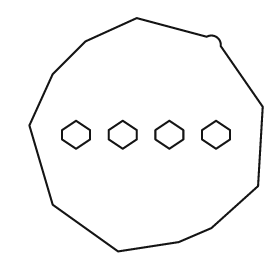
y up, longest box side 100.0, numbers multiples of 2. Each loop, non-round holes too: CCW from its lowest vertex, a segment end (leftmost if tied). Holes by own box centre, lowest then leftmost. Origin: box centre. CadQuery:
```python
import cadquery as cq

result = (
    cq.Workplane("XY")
    .moveTo(-12.0, -50.0)
    .lineTo(14.0, -46.0)
    .lineTo(28.0, -40.0)
    .lineTo(48.0, -22.0)
    .lineTo(50.0, 12.0)
    .lineTo(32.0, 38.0)
    .threePointArc((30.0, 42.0), (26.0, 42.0))
    .lineTo(-4.0, 50.0)
    .lineTo(-26.0, 40.0)
    .lineTo(-40.0, 26.0)
    .lineTo(-50.0, 4.0)
    .lineTo(-40.0, -30.0)
    .close()
    .moveTo(-30.0, -6.0)
    .lineTo(-24.0, -2.0)
    .lineTo(-24.0, 2.0)
    .lineTo(-30.0, 6.0)
    .lineTo(-36.0, 2.0)
    .lineTo(-36.0, -2.0)
    .close()
    .moveTo(-10.0, -6.0)
    .lineTo(-4.0, -2.0)
    .lineTo(-4.0, 2.0)
    .lineTo(-10.0, 6.0)
    .lineTo(-16.0, 2.0)
    .lineTo(-16.0, -2.0)
    .close()
    .moveTo(10.0, -6.0)
    .lineTo(16.0, -2.0)
    .lineTo(16.0, 2.0)
    .lineTo(10.0, 6.0)
    .lineTo(4.0, 2.0)
    .lineTo(4.0, -2.0)
    .close()
    .moveTo(30.0, -6.0)
    .lineTo(36.0, -2.0)
    .lineTo(36.0, 2.0)
    .lineTo(30.0, 6.0)
    .lineTo(24.0, 2.0)
    .lineTo(24.0, -2.0)
    .close()
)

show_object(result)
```